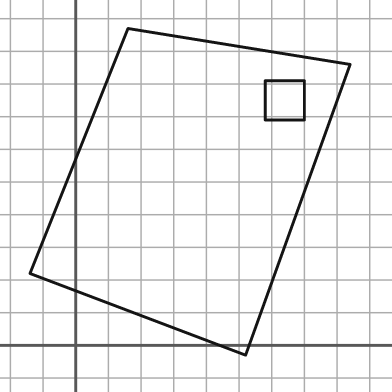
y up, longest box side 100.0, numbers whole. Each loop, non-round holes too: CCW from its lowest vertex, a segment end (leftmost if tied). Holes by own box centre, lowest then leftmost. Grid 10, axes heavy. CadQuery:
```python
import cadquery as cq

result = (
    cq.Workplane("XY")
    .moveTo(52.0, -3.0)
    .lineTo(84.0, 86.0)
    .lineTo(16.0, 97.0)
    .lineTo(-14.0, 22.0)
    .close()
    .moveTo(58.0, 69.0)
    .lineTo(70.0, 69.0)
    .lineTo(70.0, 81.0)
    .lineTo(58.0, 81.0)
    .close()
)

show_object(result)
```